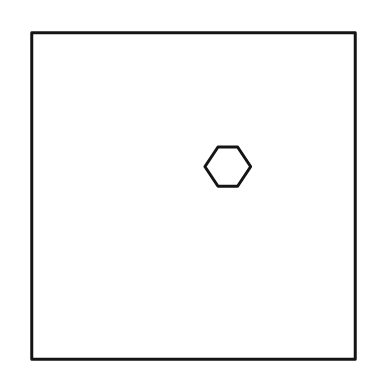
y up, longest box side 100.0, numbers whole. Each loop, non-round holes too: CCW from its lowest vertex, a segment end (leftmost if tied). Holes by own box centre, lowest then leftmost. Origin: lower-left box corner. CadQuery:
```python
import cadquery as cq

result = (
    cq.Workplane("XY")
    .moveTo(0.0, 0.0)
    .lineTo(99.0, 0.0)
    .lineTo(99.0, 100.0)
    .lineTo(0.0, 100.0)
    .close()
    .moveTo(57.0, 53.0)
    .lineTo(63.0, 53.0)
    .lineTo(67.0, 59.0)
    .lineTo(63.0, 65.0)
    .lineTo(57.0, 65.0)
    .lineTo(53.0, 59.0)
    .close()
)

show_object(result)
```